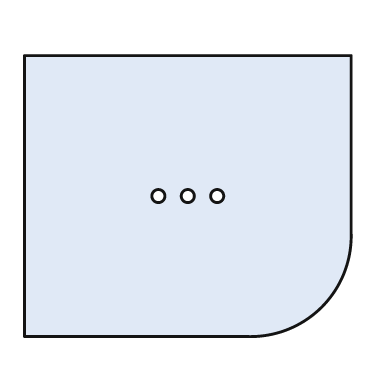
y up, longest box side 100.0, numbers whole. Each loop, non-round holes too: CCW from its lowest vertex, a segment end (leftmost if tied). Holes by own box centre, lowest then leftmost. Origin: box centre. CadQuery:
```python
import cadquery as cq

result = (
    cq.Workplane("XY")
    .moveTo(-50.0, -43.0)
    .lineTo(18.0, -43.0)
    .threePointArc((41.0, -34.0), (50.0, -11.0))
    .lineTo(50.0, 43.0)
    .lineTo(-50.0, 43.0)
    .close()
    .moveTo(-9.0, 0.0)
    .circle(2.0)
    .moveTo(0.0, 0.0)
    .circle(2.0)
    .moveTo(9.0, 0.0)
    .circle(2.0)
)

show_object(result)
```